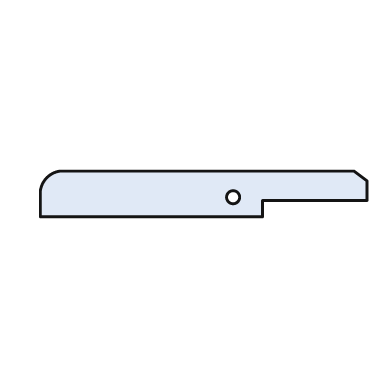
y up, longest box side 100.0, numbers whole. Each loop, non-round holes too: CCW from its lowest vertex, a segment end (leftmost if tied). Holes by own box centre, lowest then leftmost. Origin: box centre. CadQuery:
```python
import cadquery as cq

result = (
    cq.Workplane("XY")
    .moveTo(-50.0, -7.0)
    .lineTo(18.0, -7.0)
    .lineTo(18.0, -2.0)
    .lineTo(50.0, -2.0)
    .lineTo(50.0, 4.0)
    .lineTo(46.0, 7.0)
    .lineTo(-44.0, 7.0)
    .threePointArc((-48.0, 5.0), (-50.0, 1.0))
    .close()
    .moveTo(9.0, -1.0)
    .circle(2.0)
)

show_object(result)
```